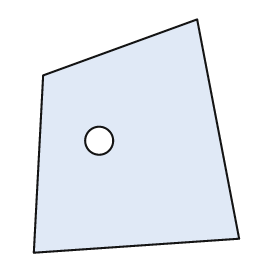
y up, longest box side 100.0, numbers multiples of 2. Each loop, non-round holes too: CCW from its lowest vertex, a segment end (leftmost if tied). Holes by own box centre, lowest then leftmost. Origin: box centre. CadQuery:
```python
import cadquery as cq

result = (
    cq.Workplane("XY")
    .moveTo(-44.0, -50.0)
    .lineTo(44.0, -44.0)
    .lineTo(26.0, 50.0)
    .lineTo(-40.0, 26.0)
    .close()
    .moveTo(-16.0, -2.0)
    .circle(6.0)
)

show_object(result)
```